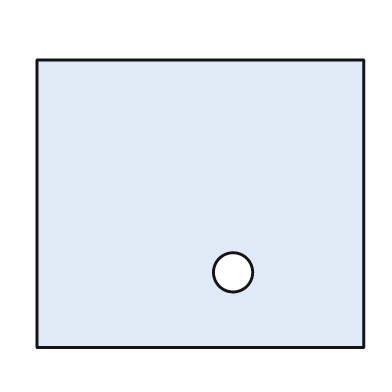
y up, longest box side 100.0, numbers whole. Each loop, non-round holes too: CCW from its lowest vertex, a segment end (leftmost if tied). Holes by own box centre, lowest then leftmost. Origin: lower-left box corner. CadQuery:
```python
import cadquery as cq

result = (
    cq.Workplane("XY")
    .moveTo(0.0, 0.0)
    .lineTo(100.0, 0.0)
    .lineTo(100.0, 88.0)
    .lineTo(0.0, 88.0)
    .close()
    .moveTo(60.0, 23.0)
    .circle(6.0)
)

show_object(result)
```